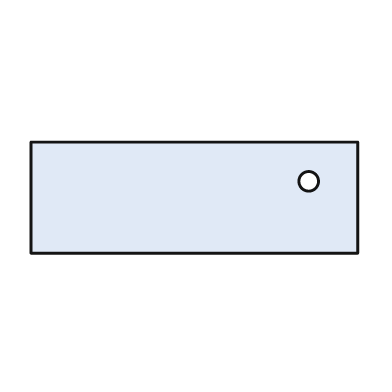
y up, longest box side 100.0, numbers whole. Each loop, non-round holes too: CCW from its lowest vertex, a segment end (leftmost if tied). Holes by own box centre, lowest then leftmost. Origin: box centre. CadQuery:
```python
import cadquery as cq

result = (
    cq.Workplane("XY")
    .moveTo(-50.0, -17.0)
    .lineTo(50.0, -17.0)
    .lineTo(50.0, 17.0)
    .lineTo(-50.0, 17.0)
    .close()
    .moveTo(35.0, 5.0)
    .circle(3.0)
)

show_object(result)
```